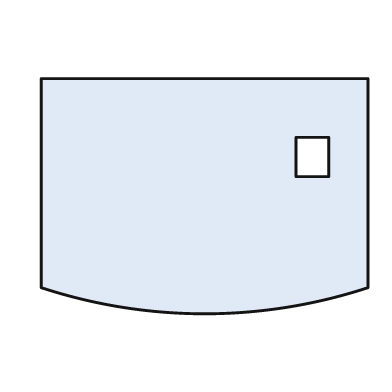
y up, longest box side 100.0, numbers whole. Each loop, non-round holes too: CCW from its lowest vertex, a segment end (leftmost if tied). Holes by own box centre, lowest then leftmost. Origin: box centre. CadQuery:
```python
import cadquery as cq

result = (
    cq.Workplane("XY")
    .moveTo(-50.0, -28.0)
    .threePointArc((0.0, -36.0), (50.0, -28.0))
    .lineTo(50.0, 36.0)
    .lineTo(-50.0, 36.0)
    .close()
    .moveTo(28.0, 6.0)
    .lineTo(38.0, 6.0)
    .lineTo(38.0, 18.0)
    .lineTo(28.0, 18.0)
    .close()
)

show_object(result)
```